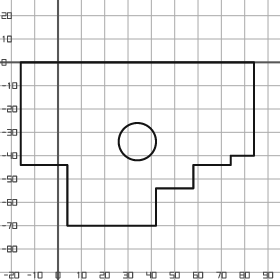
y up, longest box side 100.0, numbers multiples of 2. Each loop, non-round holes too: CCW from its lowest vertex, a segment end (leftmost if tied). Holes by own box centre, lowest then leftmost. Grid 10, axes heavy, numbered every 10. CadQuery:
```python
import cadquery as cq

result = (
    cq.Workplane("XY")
    .moveTo(4.0, -70.0)
    .lineTo(42.0, -70.0)
    .lineTo(42.0, -54.0)
    .lineTo(58.0, -54.0)
    .lineTo(58.0, -44.0)
    .lineTo(74.0, -44.0)
    .lineTo(74.0, -40.0)
    .lineTo(84.0, -40.0)
    .lineTo(84.0, 0.0)
    .lineTo(-16.0, 0.0)
    .lineTo(-16.0, -44.0)
    .lineTo(4.0, -44.0)
    .close()
    .moveTo(34.0, -34.0)
    .circle(8.0)
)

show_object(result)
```